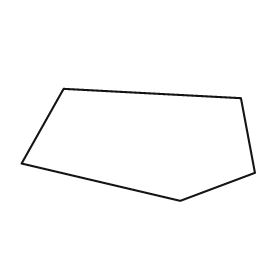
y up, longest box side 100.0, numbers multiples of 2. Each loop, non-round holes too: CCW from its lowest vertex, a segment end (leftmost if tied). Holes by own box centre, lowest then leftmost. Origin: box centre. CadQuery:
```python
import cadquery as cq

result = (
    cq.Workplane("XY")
    .moveTo(18.0, -24.0)
    .lineTo(50.0, -12.0)
    .lineTo(44.0, 20.0)
    .lineTo(-32.0, 24.0)
    .lineTo(-50.0, -8.0)
    .close()
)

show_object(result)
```